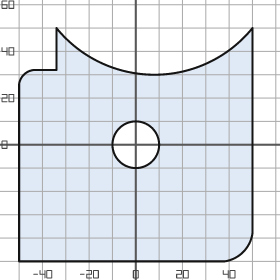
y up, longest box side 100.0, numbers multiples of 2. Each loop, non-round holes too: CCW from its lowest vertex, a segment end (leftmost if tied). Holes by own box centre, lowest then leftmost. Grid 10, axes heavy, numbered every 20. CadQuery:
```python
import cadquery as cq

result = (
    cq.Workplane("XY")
    .moveTo(-50.0, -50.0)
    .lineTo(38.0, -50.0)
    .threePointArc((46.0, -46.0), (50.0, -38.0))
    .lineTo(50.0, 50.0)
    .threePointArc((8.0, 30.0), (-34.0, 50.0))
    .lineTo(-34.0, 32.0)
    .lineTo(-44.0, 32.0)
    .threePointArc((-48.0, 30.0), (-50.0, 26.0))
    .close()
    .moveTo(0.0, 0.0)
    .circle(10.0)
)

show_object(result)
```